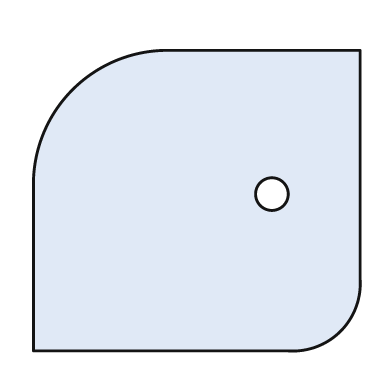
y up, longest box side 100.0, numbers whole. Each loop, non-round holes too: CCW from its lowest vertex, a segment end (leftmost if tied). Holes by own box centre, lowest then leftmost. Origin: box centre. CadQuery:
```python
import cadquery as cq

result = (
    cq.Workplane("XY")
    .moveTo(-50.0, -46.0)
    .lineTo(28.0, -46.0)
    .threePointArc((44.0, -40.0), (50.0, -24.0))
    .lineTo(50.0, 46.0)
    .lineTo(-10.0, 46.0)
    .threePointArc((-38.0, 34.0), (-50.0, 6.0))
    .close()
    .moveTo(23.0, 2.0)
    .circle(5.0)
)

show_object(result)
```